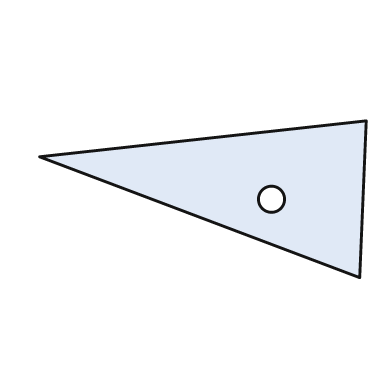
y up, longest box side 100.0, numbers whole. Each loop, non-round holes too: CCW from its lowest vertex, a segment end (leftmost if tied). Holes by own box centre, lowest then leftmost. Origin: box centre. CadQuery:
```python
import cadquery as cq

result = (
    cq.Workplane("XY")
    .moveTo(48.0, -24.0)
    .lineTo(50.0, 24.0)
    .lineTo(-50.0, 13.0)
    .close()
    .moveTo(21.0, 0.0)
    .circle(4.0)
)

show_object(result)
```